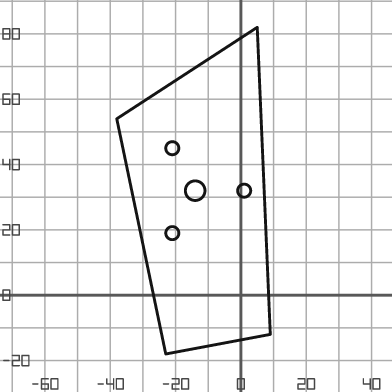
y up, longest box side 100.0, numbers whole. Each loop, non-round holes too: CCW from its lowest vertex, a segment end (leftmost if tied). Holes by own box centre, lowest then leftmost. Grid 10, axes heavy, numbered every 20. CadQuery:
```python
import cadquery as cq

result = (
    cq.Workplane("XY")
    .moveTo(-23.0, -18.0)
    .lineTo(9.0, -12.0)
    .lineTo(5.0, 82.0)
    .lineTo(-38.0, 54.0)
    .close()
    .moveTo(-21.0, 19.0)
    .circle(2.0)
    .moveTo(-14.0, 32.0)
    .circle(3.0)
    .moveTo(1.0, 32.0)
    .circle(2.0)
    .moveTo(-21.0, 45.0)
    .circle(2.0)
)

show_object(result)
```